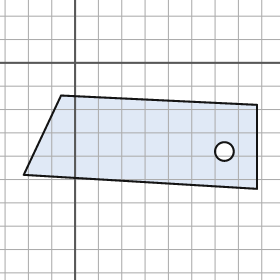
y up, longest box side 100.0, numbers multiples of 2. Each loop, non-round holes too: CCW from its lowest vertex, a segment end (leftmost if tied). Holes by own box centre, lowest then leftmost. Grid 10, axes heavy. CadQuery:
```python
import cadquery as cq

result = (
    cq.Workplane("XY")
    .moveTo(78.0, -54.0)
    .lineTo(78.0, -18.0)
    .lineTo(-6.0, -14.0)
    .lineTo(-22.0, -48.0)
    .close()
    .moveTo(64.0, -38.0)
    .circle(4.0)
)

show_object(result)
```